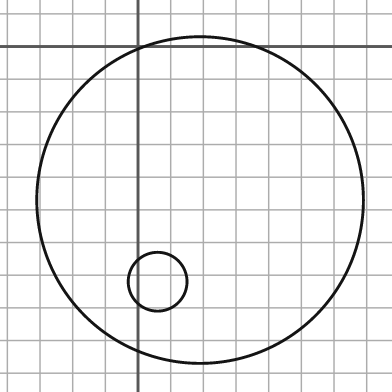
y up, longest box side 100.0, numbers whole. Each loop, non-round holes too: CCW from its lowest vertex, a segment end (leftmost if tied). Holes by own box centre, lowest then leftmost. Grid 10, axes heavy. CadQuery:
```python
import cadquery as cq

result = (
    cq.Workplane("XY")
    .moveTo(19.0, -47.0)
    .circle(50.0)
    .moveTo(6.0, -72.0)
    .circle(9.0)
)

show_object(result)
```